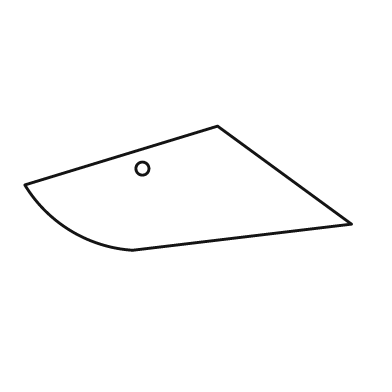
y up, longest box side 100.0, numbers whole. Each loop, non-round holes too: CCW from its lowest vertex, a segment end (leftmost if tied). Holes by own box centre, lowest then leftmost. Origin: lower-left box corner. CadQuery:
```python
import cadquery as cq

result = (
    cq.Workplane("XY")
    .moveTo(33.0, 0.0)
    .lineTo(100.0, 8.0)
    .lineTo(59.0, 38.0)
    .lineTo(0.0, 20.0)
    .threePointArc((14.0, 6.0), (33.0, 0.0))
    .close()
    .moveTo(36.0, 25.0)
    .circle(2.0)
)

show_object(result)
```